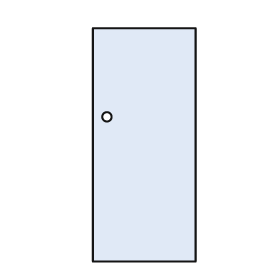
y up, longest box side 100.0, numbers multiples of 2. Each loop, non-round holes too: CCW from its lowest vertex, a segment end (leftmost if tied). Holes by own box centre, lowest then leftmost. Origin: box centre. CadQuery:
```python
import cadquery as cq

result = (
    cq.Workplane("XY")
    .moveTo(-22.0, -50.0)
    .lineTo(22.0, -50.0)
    .lineTo(22.0, 50.0)
    .lineTo(-22.0, 50.0)
    .close()
    .moveTo(-16.0, 12.0)
    .circle(2.0)
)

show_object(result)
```